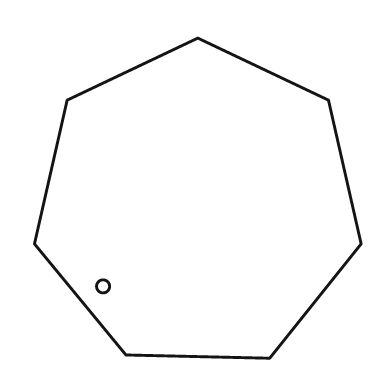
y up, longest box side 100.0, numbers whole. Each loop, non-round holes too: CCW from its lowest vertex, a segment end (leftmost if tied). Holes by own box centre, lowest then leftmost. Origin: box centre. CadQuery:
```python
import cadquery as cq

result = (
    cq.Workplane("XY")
    .moveTo(22.0, -49.0)
    .lineTo(50.0, -14.0)
    .lineTo(40.0, 30.0)
    .lineTo(0.0, 49.0)
    .lineTo(-40.0, 30.0)
    .lineTo(-50.0, -14.0)
    .lineTo(-22.0, -48.0)
    .close()
    .moveTo(-29.0, -27.0)
    .circle(2.0)
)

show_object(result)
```